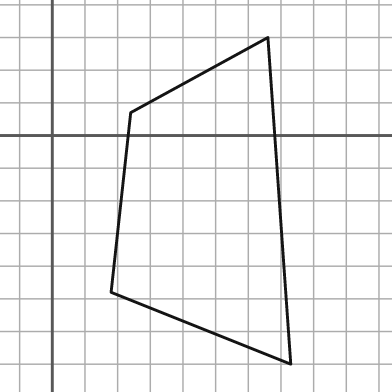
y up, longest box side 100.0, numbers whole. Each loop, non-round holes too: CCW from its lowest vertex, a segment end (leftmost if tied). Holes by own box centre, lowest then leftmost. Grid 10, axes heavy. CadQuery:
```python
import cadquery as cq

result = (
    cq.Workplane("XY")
    .moveTo(73.0, -70.0)
    .lineTo(66.0, 30.0)
    .lineTo(24.0, 7.0)
    .lineTo(18.0, -48.0)
    .close()
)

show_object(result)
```